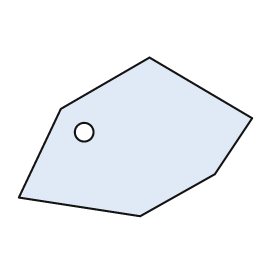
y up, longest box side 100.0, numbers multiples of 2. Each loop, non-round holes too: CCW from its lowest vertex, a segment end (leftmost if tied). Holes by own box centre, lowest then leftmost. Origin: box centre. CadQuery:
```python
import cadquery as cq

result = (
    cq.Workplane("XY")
    .moveTo(2.0, -34.0)
    .lineTo(34.0, -16.0)
    .lineTo(50.0, 8.0)
    .lineTo(6.0, 34.0)
    .lineTo(-32.0, 12.0)
    .lineTo(-50.0, -26.0)
    .close()
    .moveTo(-22.0, 2.0)
    .circle(4.0)
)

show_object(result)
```